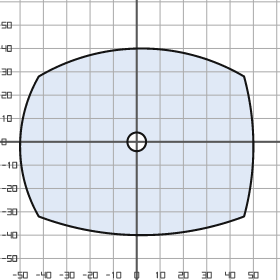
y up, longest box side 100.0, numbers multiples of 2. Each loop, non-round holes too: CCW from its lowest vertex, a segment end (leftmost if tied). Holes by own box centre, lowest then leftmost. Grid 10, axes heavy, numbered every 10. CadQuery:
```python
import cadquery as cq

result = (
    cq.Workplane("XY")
    .moveTo(-42.0, -32.0)
    .threePointArc((2.0, -40.0), (46.0, -32.0))
    .threePointArc((50.0, -2.0), (46.0, 28.0))
    .threePointArc((2.0, 40.0), (-42.0, 28.0))
    .threePointArc((-50.0, -2.0), (-42.0, -32.0))
    .close()
    .moveTo(0.0, 0.0)
    .circle(4.0)
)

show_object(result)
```